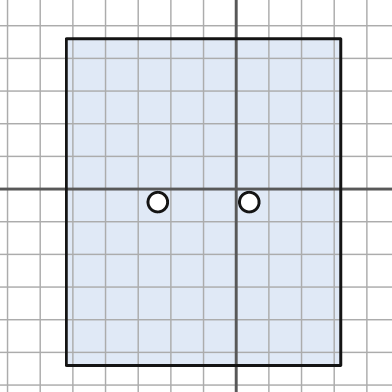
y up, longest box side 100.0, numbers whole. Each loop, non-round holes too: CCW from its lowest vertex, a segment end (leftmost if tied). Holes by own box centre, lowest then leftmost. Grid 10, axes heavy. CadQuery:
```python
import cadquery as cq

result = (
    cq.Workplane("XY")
    .moveTo(-52.0, -54.0)
    .lineTo(32.0, -54.0)
    .lineTo(32.0, 46.0)
    .lineTo(-52.0, 46.0)
    .close()
    .moveTo(-24.0, -4.0)
    .circle(3.0)
    .moveTo(4.0, -4.0)
    .circle(3.0)
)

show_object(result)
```